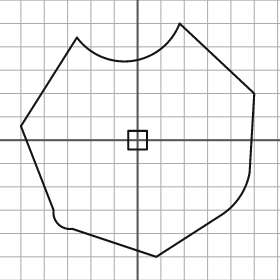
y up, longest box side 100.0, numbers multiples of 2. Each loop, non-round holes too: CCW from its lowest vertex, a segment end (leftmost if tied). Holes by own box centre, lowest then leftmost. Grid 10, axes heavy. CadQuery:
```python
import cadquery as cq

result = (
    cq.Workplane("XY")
    .moveTo(8.0, -50.0)
    .lineTo(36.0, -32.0)
    .threePointArc((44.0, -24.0), (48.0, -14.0))
    .lineTo(50.0, 20.0)
    .lineTo(18.0, 50.0)
    .threePointArc((-2.0, 34.0), (-26.0, 44.0))
    .lineTo(-50.0, 6.0)
    .lineTo(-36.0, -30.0)
    .threePointArc((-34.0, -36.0), (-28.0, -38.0))
    .close()
    .moveTo(-4.0, -4.0)
    .lineTo(4.0, -4.0)
    .lineTo(4.0, 4.0)
    .lineTo(-4.0, 4.0)
    .close()
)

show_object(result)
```